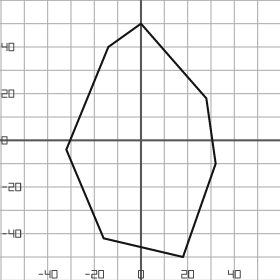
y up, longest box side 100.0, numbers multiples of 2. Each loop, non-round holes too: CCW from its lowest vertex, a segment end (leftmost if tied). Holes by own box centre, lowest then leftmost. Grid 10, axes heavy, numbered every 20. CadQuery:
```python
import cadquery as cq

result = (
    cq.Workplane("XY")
    .moveTo(18.0, -50.0)
    .lineTo(32.0, -10.0)
    .lineTo(28.0, 18.0)
    .lineTo(0.0, 50.0)
    .lineTo(-14.0, 40.0)
    .lineTo(-32.0, -4.0)
    .lineTo(-16.0, -42.0)
    .close()
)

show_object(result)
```